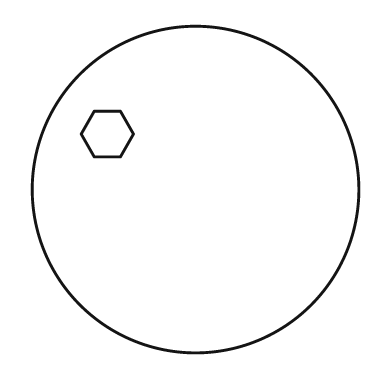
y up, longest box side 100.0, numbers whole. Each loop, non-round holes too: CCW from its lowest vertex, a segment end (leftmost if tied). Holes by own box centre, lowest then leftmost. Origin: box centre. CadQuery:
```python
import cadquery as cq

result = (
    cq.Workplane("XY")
    .moveTo(0.0, 0.0)
    .circle(50.0)
    .moveTo(-31.0, 10.0)
    .lineTo(-23.0, 10.0)
    .lineTo(-19.0, 17.0)
    .lineTo(-23.0, 24.0)
    .lineTo(-31.0, 24.0)
    .lineTo(-35.0, 17.0)
    .close()
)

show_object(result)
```